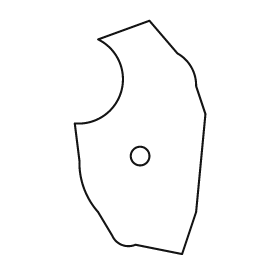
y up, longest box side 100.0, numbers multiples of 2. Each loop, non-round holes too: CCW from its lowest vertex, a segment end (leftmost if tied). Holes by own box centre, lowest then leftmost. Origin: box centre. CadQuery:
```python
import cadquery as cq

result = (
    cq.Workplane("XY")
    .moveTo(18.0, -50.0)
    .lineTo(24.0, -32.0)
    .lineTo(28.0, 10.0)
    .lineTo(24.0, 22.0)
    .threePointArc((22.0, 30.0), (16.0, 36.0))
    .lineTo(4.0, 50.0)
    .lineTo(-18.0, 42.0)
    .threePointArc((-8.0, 20.0), (-28.0, 6.0))
    .lineTo(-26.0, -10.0)
    .threePointArc((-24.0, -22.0), (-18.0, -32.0))
    .lineTo(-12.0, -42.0)
    .threePointArc((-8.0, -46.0), (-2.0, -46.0))
    .close()
    .moveTo(0.0, -8.0)
    .circle(4.0)
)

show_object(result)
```